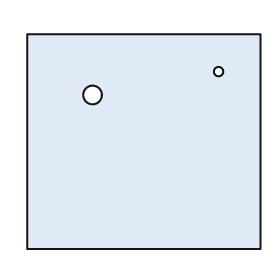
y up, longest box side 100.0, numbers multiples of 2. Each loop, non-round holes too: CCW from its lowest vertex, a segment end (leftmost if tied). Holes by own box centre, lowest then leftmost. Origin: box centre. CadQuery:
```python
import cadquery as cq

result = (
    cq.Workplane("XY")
    .moveTo(-50.0, -46.0)
    .lineTo(50.0, -46.0)
    .lineTo(50.0, 46.0)
    .lineTo(-50.0, 46.0)
    .close()
    .moveTo(-22.0, 20.0)
    .circle(4.0)
    .moveTo(32.0, 30.0)
    .circle(2.0)
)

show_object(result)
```